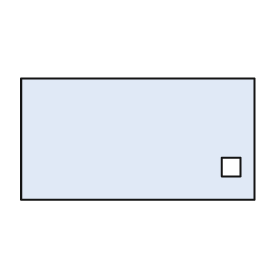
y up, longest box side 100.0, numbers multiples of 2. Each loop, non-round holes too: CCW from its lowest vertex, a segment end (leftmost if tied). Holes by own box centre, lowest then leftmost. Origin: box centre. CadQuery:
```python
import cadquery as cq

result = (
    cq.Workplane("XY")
    .moveTo(-50.0, -26.0)
    .lineTo(50.0, -26.0)
    .lineTo(50.0, 26.0)
    .lineTo(-50.0, 26.0)
    .close()
    .moveTo(36.0, -16.0)
    .lineTo(44.0, -16.0)
    .lineTo(44.0, -8.0)
    .lineTo(36.0, -8.0)
    .close()
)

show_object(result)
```